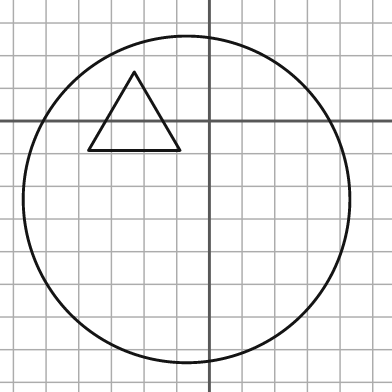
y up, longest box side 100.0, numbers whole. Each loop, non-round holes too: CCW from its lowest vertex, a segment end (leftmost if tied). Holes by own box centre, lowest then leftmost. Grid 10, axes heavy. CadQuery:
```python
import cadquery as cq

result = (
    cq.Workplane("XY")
    .moveTo(-7.0, -24.0)
    .circle(50.0)
    .moveTo(-37.0, -9.0)
    .lineTo(-9.0, -9.0)
    .lineTo(-23.0, 15.0)
    .close()
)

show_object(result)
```